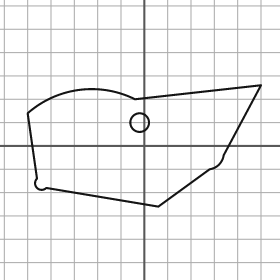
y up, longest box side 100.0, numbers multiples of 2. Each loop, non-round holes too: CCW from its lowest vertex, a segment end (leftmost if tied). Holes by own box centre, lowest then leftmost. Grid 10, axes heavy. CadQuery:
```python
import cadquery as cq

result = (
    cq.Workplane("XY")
    .moveTo(6.0, -26.0)
    .lineTo(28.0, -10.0)
    .threePointArc((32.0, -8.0), (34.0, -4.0))
    .lineTo(50.0, 26.0)
    .lineTo(-4.0, 20.0)
    .threePointArc((-28.0, 24.0), (-50.0, 14.0))
    .lineTo(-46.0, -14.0)
    .threePointArc((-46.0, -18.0), (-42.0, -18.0))
    .close()
    .moveTo(-2.0, 10.0)
    .circle(4.0)
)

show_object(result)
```